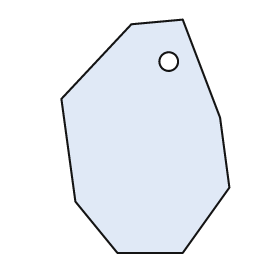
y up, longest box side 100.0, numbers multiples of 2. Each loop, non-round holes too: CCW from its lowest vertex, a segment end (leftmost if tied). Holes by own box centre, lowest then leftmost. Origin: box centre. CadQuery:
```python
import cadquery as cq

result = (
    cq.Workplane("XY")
    .moveTo(-12.0, -50.0)
    .lineTo(16.0, -50.0)
    .lineTo(36.0, -22.0)
    .lineTo(32.0, 8.0)
    .lineTo(16.0, 50.0)
    .lineTo(-6.0, 48.0)
    .lineTo(-36.0, 16.0)
    .lineTo(-30.0, -28.0)
    .close()
    .moveTo(10.0, 32.0)
    .circle(4.0)
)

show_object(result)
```